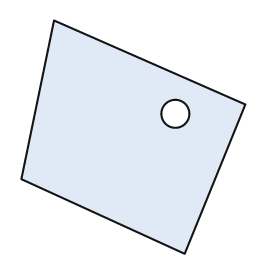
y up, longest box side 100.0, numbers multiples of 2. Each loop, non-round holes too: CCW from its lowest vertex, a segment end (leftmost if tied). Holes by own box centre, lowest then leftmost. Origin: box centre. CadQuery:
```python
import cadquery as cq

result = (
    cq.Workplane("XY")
    .moveTo(22.0, -50.0)
    .lineTo(48.0, 14.0)
    .lineTo(-34.0, 50.0)
    .lineTo(-48.0, -18.0)
    .close()
    .moveTo(18.0, 10.0)
    .circle(6.0)
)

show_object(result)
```